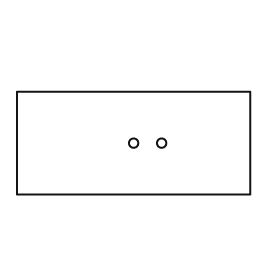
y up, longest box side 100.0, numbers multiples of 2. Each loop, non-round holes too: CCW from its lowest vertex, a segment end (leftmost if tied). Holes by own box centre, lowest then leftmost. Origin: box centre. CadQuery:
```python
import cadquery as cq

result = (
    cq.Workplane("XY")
    .moveTo(-50.0, -22.0)
    .lineTo(50.0, -22.0)
    .lineTo(50.0, 22.0)
    .lineTo(-50.0, 22.0)
    .close()
    .moveTo(0.0, 0.0)
    .circle(2.0)
    .moveTo(12.0, 0.0)
    .circle(2.0)
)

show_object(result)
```